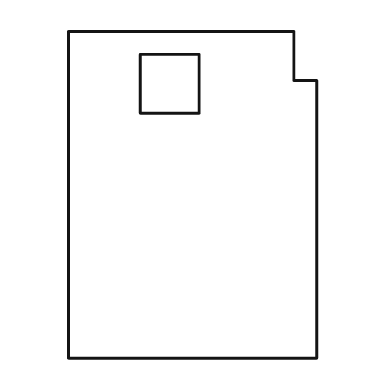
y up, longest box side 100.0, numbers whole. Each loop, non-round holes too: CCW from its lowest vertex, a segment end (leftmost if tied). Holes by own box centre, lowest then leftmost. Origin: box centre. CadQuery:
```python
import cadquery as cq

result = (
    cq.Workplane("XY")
    .moveTo(-38.0, -50.0)
    .lineTo(38.0, -50.0)
    .lineTo(38.0, 35.0)
    .lineTo(31.0, 35.0)
    .lineTo(31.0, 50.0)
    .lineTo(-38.0, 50.0)
    .close()
    .moveTo(-16.0, 25.0)
    .lineTo(2.0, 25.0)
    .lineTo(2.0, 43.0)
    .lineTo(-16.0, 43.0)
    .close()
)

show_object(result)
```